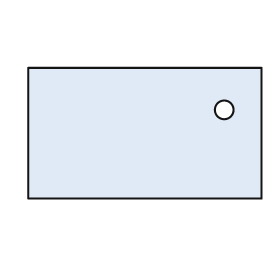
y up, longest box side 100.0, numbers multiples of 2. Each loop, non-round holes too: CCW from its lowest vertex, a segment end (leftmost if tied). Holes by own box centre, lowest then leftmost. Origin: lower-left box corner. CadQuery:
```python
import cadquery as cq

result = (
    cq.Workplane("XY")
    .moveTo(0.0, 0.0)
    .lineTo(100.0, 0.0)
    .lineTo(100.0, 56.0)
    .lineTo(0.0, 56.0)
    .close()
    .moveTo(84.0, 38.0)
    .circle(4.0)
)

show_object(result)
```